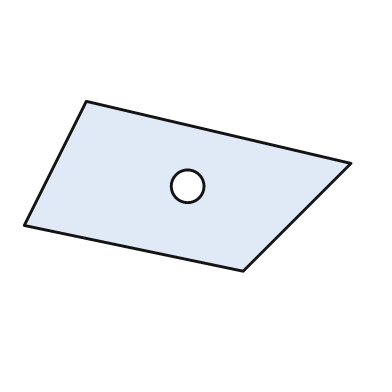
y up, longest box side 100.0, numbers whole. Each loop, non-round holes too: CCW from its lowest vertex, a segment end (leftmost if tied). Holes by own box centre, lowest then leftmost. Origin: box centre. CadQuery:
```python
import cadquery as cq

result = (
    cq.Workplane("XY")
    .moveTo(17.0, -26.0)
    .lineTo(50.0, 7.0)
    .lineTo(-31.0, 26.0)
    .lineTo(-50.0, -12.0)
    .close()
    .moveTo(0.0, 0.0)
    .circle(5.0)
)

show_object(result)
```